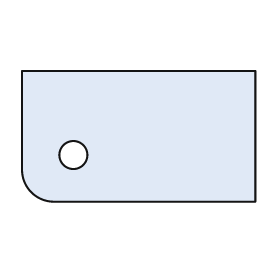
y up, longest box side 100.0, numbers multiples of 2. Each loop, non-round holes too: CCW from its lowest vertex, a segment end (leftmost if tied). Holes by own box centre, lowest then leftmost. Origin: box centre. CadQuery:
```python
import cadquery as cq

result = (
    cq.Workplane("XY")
    .moveTo(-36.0, -28.0)
    .lineTo(50.0, -28.0)
    .lineTo(50.0, 28.0)
    .lineTo(-50.0, 28.0)
    .lineTo(-50.0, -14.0)
    .threePointArc((-46.0, -24.0), (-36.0, -28.0))
    .close()
    .moveTo(-28.0, -8.0)
    .circle(6.0)
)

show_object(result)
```